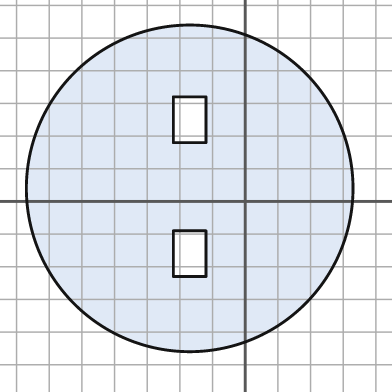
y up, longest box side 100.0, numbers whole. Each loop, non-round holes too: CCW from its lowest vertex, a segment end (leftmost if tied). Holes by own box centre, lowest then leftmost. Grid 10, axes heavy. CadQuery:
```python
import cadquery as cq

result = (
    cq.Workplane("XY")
    .moveTo(-17.0, 4.0)
    .circle(50.0)
    .moveTo(-22.0, -23.0)
    .lineTo(-12.0, -23.0)
    .lineTo(-12.0, -9.0)
    .lineTo(-22.0, -9.0)
    .close()
    .moveTo(-22.0, 18.0)
    .lineTo(-12.0, 18.0)
    .lineTo(-12.0, 32.0)
    .lineTo(-22.0, 32.0)
    .close()
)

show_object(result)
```